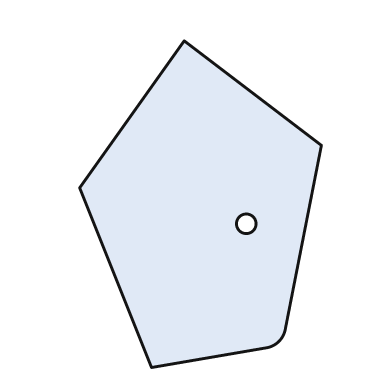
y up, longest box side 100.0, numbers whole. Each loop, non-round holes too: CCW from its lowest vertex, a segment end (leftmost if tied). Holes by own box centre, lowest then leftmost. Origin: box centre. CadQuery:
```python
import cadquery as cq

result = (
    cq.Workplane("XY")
    .moveTo(-15.0, -50.0)
    .lineTo(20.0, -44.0)
    .threePointArc((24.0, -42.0), (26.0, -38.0))
    .lineTo(37.0, 18.0)
    .lineTo(-5.0, 50.0)
    .lineTo(-37.0, 5.0)
    .close()
    .moveTo(14.0, -6.0)
    .circle(3.0)
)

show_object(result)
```